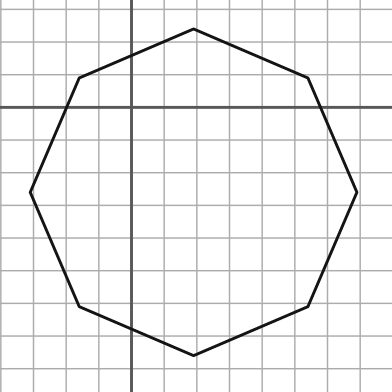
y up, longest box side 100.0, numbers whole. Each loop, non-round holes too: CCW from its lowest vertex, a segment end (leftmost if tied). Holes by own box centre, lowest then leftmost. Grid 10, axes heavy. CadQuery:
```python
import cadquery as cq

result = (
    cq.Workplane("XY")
    .moveTo(19.0, -76.0)
    .lineTo(54.0, -61.0)
    .lineTo(69.0, -26.0)
    .lineTo(54.0, 9.0)
    .lineTo(19.0, 24.0)
    .lineTo(-16.0, 9.0)
    .lineTo(-31.0, -26.0)
    .lineTo(-16.0, -61.0)
    .close()
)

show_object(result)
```